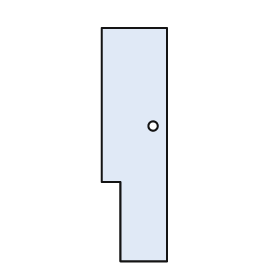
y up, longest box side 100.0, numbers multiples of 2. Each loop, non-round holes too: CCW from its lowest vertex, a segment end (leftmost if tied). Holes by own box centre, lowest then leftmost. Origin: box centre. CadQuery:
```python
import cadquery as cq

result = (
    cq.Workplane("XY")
    .moveTo(-6.0, -50.0)
    .lineTo(14.0, -50.0)
    .lineTo(14.0, 50.0)
    .lineTo(-14.0, 50.0)
    .lineTo(-14.0, -16.0)
    .lineTo(-6.0, -16.0)
    .close()
    .moveTo(8.0, 8.0)
    .circle(2.0)
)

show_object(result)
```